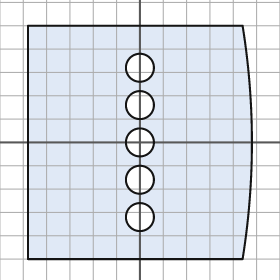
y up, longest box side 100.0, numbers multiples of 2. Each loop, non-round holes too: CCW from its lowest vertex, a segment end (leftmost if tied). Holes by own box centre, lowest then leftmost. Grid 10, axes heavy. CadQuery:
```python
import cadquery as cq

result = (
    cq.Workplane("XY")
    .moveTo(-48.0, -50.0)
    .lineTo(44.0, -50.0)
    .threePointArc((48.0, 0.0), (44.0, 50.0))
    .lineTo(-48.0, 50.0)
    .close()
    .moveTo(0.0, -32.0)
    .circle(6.0)
    .moveTo(0.0, -16.0)
    .circle(6.0)
    .moveTo(0.0, 0.0)
    .circle(6.0)
    .moveTo(0.0, 16.0)
    .circle(6.0)
    .moveTo(0.0, 32.0)
    .circle(6.0)
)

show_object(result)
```